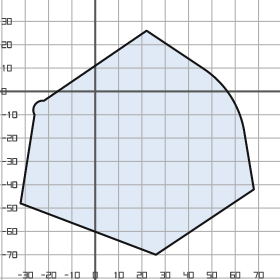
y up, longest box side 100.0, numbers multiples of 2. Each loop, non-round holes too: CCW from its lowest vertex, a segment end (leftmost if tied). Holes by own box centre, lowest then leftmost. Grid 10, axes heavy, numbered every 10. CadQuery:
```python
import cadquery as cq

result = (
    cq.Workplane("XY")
    .moveTo(26.0, -70.0)
    .lineTo(68.0, -42.0)
    .lineTo(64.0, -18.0)
    .threePointArc((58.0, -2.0), (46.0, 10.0))
    .lineTo(22.0, 26.0)
    .lineTo(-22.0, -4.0)
    .threePointArc((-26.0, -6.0), (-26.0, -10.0))
    .lineTo(-32.0, -48.0)
    .close()
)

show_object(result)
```